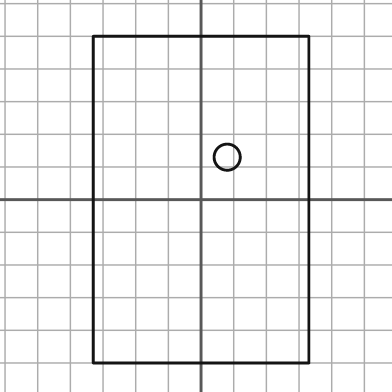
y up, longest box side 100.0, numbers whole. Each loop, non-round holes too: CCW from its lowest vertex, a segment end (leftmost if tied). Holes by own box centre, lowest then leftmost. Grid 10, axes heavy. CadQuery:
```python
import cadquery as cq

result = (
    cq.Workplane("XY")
    .moveTo(-33.0, -50.0)
    .lineTo(33.0, -50.0)
    .lineTo(33.0, 50.0)
    .lineTo(-33.0, 50.0)
    .close()
    .moveTo(8.0, 13.0)
    .circle(4.0)
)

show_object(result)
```